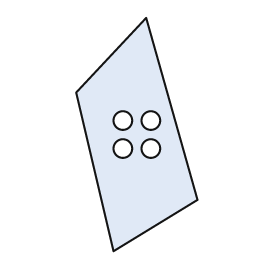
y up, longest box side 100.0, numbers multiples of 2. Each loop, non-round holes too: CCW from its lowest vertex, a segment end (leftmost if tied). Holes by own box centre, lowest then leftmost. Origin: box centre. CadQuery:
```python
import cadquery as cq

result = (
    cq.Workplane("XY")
    .moveTo(-10.0, -50.0)
    .lineTo(26.0, -28.0)
    .lineTo(4.0, 50.0)
    .lineTo(-26.0, 18.0)
    .close()
    .moveTo(-6.0, -6.0)
    .circle(4.0)
    .moveTo(6.0, -6.0)
    .circle(4.0)
    .moveTo(-6.0, 6.0)
    .circle(4.0)
    .moveTo(6.0, 6.0)
    .circle(4.0)
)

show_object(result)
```